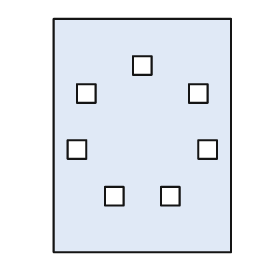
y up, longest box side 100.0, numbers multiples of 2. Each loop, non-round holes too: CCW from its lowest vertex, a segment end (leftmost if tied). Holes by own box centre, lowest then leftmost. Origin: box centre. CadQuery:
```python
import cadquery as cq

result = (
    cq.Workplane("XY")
    .moveTo(-38.0, -50.0)
    .lineTo(38.0, -50.0)
    .lineTo(38.0, 50.0)
    .lineTo(-38.0, 50.0)
    .close()
    .moveTo(-16.0, -30.0)
    .lineTo(-8.0, -30.0)
    .lineTo(-8.0, -22.0)
    .lineTo(-16.0, -22.0)
    .close()
    .moveTo(8.0, -30.0)
    .lineTo(16.0, -30.0)
    .lineTo(16.0, -22.0)
    .lineTo(8.0, -22.0)
    .close()
    .moveTo(-32.0, -10.0)
    .lineTo(-24.0, -10.0)
    .lineTo(-24.0, -2.0)
    .lineTo(-32.0, -2.0)
    .close()
    .moveTo(24.0, -10.0)
    .lineTo(32.0, -10.0)
    .lineTo(32.0, -2.0)
    .lineTo(24.0, -2.0)
    .close()
    .moveTo(-28.0, 14.0)
    .lineTo(-20.0, 14.0)
    .lineTo(-20.0, 22.0)
    .lineTo(-28.0, 22.0)
    .close()
    .moveTo(20.0, 14.0)
    .lineTo(28.0, 14.0)
    .lineTo(28.0, 22.0)
    .lineTo(20.0, 22.0)
    .close()
    .moveTo(-4.0, 26.0)
    .lineTo(4.0, 26.0)
    .lineTo(4.0, 34.0)
    .lineTo(-4.0, 34.0)
    .close()
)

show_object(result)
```